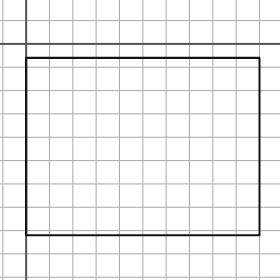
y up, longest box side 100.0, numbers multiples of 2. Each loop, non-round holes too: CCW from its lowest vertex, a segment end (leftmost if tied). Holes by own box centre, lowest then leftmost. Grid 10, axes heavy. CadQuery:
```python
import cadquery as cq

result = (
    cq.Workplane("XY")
    .moveTo(0.0, -82.0)
    .lineTo(100.0, -82.0)
    .lineTo(100.0, -6.0)
    .lineTo(0.0, -6.0)
    .close()
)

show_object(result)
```